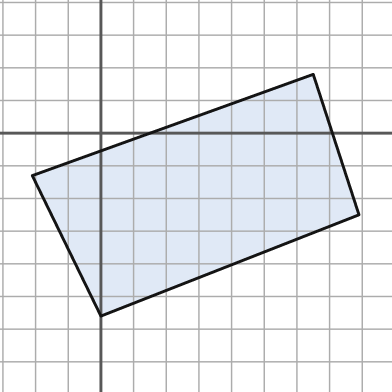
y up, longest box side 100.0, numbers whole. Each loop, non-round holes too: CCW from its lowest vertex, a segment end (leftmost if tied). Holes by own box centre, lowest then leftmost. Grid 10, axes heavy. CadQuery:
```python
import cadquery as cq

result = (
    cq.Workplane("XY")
    .moveTo(0.0, -56.0)
    .lineTo(79.0, -25.0)
    .lineTo(65.0, 18.0)
    .lineTo(-21.0, -13.0)
    .close()
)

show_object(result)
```